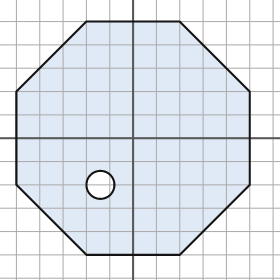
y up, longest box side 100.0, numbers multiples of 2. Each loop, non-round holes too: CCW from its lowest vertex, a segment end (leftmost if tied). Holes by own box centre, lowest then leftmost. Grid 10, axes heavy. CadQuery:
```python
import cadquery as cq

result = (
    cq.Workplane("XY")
    .moveTo(-20.0, -50.0)
    .lineTo(20.0, -50.0)
    .lineTo(50.0, -20.0)
    .lineTo(50.0, 20.0)
    .lineTo(20.0, 50.0)
    .lineTo(-20.0, 50.0)
    .lineTo(-50.0, 20.0)
    .lineTo(-50.0, -20.0)
    .close()
    .moveTo(-14.0, -20.0)
    .circle(6.0)
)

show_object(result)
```